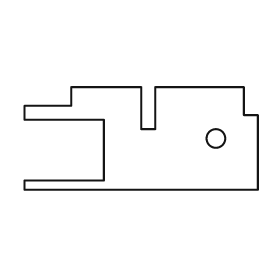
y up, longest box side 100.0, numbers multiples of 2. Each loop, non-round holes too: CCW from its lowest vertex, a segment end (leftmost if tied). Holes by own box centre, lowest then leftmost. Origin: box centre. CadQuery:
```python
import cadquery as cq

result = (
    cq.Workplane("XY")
    .moveTo(-50.0, -22.0)
    .lineTo(50.0, -22.0)
    .lineTo(50.0, 10.0)
    .lineTo(44.0, 10.0)
    .lineTo(44.0, 22.0)
    .lineTo(6.0, 22.0)
    .lineTo(6.0, 4.0)
    .lineTo(0.0, 4.0)
    .lineTo(0.0, 22.0)
    .lineTo(-30.0, 22.0)
    .lineTo(-30.0, 14.0)
    .lineTo(-50.0, 14.0)
    .lineTo(-50.0, 8.0)
    .lineTo(-16.0, 8.0)
    .lineTo(-16.0, -18.0)
    .lineTo(-50.0, -18.0)
    .close()
    .moveTo(32.0, 0.0)
    .circle(4.0)
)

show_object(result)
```